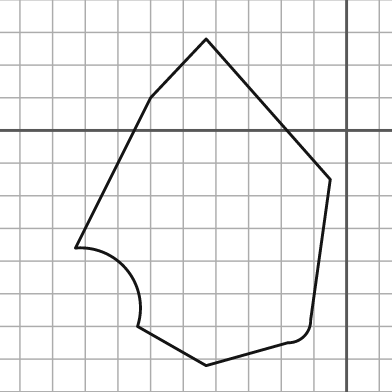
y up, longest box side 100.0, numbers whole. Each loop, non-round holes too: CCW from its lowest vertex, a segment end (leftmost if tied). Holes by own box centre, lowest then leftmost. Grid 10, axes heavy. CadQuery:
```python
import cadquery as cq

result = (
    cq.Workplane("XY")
    .moveTo(-43.0, -72.0)
    .lineTo(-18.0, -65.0)
    .threePointArc((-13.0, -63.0), (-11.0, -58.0))
    .lineTo(-5.0, -15.0)
    .lineTo(-43.0, 28.0)
    .lineTo(-60.0, 10.0)
    .lineTo(-83.0, -36.0)
    .threePointArc((-67.0, -43.0), (-64.0, -60.0))
    .close()
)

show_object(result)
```